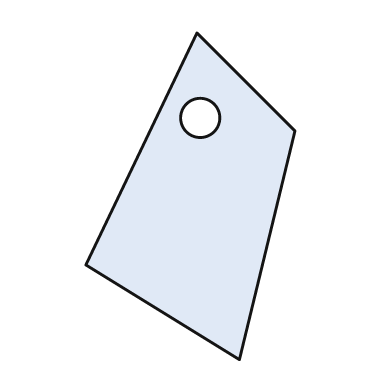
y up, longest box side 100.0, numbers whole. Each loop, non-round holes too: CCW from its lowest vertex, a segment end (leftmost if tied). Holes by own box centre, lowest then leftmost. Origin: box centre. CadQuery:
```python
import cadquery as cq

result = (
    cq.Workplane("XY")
    .moveTo(15.0, -50.0)
    .lineTo(32.0, 20.0)
    .lineTo(2.0, 50.0)
    .lineTo(-32.0, -21.0)
    .close()
    .moveTo(3.0, 24.0)
    .circle(6.0)
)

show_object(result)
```